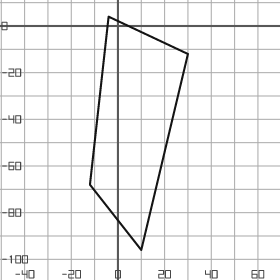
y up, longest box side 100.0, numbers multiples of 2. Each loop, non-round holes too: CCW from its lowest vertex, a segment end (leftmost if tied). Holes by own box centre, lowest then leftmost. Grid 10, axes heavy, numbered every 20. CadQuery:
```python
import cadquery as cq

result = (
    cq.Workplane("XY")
    .moveTo(10.0, -96.0)
    .lineTo(30.0, -12.0)
    .lineTo(-4.0, 4.0)
    .lineTo(-12.0, -68.0)
    .close()
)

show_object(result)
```